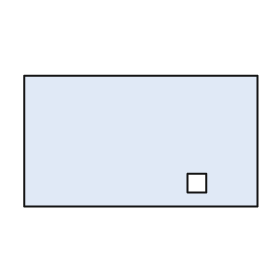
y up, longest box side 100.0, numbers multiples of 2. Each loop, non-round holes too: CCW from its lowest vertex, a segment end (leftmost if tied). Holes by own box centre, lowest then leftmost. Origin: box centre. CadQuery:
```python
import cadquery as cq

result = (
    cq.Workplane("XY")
    .moveTo(-50.0, -28.0)
    .lineTo(50.0, -28.0)
    .lineTo(50.0, 28.0)
    .lineTo(-50.0, 28.0)
    .close()
    .moveTo(20.0, -22.0)
    .lineTo(28.0, -22.0)
    .lineTo(28.0, -14.0)
    .lineTo(20.0, -14.0)
    .close()
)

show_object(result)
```